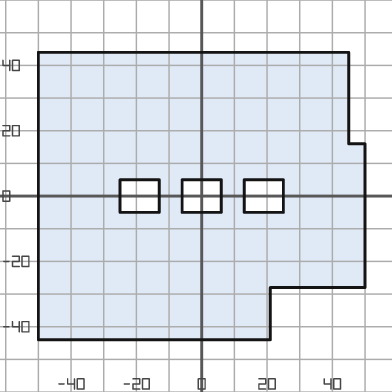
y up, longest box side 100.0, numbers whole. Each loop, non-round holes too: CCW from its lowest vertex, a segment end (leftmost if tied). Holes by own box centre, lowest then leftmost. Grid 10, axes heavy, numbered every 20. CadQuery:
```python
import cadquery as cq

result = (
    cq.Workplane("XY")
    .moveTo(-50.0, -44.0)
    .lineTo(21.0, -44.0)
    .lineTo(21.0, -28.0)
    .lineTo(50.0, -28.0)
    .lineTo(50.0, 16.0)
    .lineTo(45.0, 16.0)
    .lineTo(45.0, 44.0)
    .lineTo(-50.0, 44.0)
    .close()
    .moveTo(-25.0, -5.0)
    .lineTo(-13.0, -5.0)
    .lineTo(-13.0, 5.0)
    .lineTo(-25.0, 5.0)
    .close()
    .moveTo(-6.0, -5.0)
    .lineTo(6.0, -5.0)
    .lineTo(6.0, 5.0)
    .lineTo(-6.0, 5.0)
    .close()
    .moveTo(13.0, -5.0)
    .lineTo(25.0, -5.0)
    .lineTo(25.0, 5.0)
    .lineTo(13.0, 5.0)
    .close()
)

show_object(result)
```